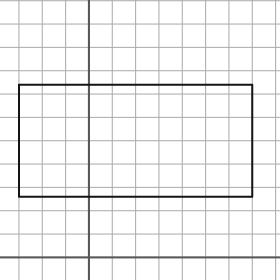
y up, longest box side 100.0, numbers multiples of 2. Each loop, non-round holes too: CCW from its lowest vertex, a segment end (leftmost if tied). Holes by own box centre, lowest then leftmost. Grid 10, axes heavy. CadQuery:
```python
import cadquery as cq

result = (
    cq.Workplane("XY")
    .moveTo(-30.0, 26.0)
    .lineTo(70.0, 26.0)
    .lineTo(70.0, 74.0)
    .lineTo(-30.0, 74.0)
    .close()
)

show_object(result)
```